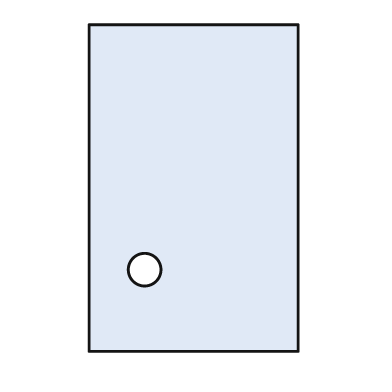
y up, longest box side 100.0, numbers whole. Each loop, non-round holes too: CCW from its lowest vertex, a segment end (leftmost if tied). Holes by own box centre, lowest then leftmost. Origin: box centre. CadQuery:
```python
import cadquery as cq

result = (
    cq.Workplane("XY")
    .moveTo(-32.0, -50.0)
    .lineTo(32.0, -50.0)
    .lineTo(32.0, 50.0)
    .lineTo(-32.0, 50.0)
    .close()
    .moveTo(-15.0, -25.0)
    .circle(5.0)
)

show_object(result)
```